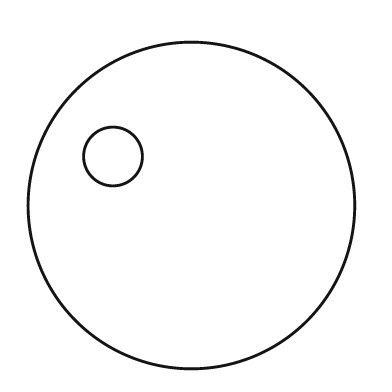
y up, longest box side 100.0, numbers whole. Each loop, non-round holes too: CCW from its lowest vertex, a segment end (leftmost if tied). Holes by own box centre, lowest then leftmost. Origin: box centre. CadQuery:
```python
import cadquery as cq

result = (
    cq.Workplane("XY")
    .moveTo(0.0, 0.0)
    .circle(50.0)
    .moveTo(-24.0, 15.0)
    .circle(9.0)
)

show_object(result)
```